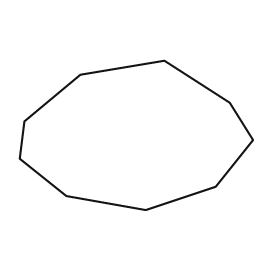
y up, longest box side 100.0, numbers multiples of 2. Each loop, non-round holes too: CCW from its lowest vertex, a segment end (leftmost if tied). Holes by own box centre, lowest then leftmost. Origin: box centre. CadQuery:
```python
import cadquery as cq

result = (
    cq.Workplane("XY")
    .moveTo(4.0, -32.0)
    .lineTo(34.0, -22.0)
    .lineTo(50.0, -2.0)
    .lineTo(40.0, 14.0)
    .lineTo(12.0, 32.0)
    .lineTo(-24.0, 26.0)
    .lineTo(-48.0, 6.0)
    .lineTo(-50.0, -10.0)
    .lineTo(-30.0, -26.0)
    .close()
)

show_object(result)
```